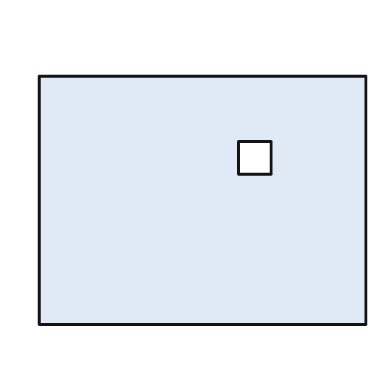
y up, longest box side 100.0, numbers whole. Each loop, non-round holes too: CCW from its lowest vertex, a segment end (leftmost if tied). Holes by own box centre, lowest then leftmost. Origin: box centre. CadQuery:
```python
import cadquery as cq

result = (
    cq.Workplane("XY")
    .moveTo(-50.0, -38.0)
    .lineTo(50.0, -38.0)
    .lineTo(50.0, 38.0)
    .lineTo(-50.0, 38.0)
    .close()
    .moveTo(11.0, 8.0)
    .lineTo(21.0, 8.0)
    .lineTo(21.0, 18.0)
    .lineTo(11.0, 18.0)
    .close()
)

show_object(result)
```